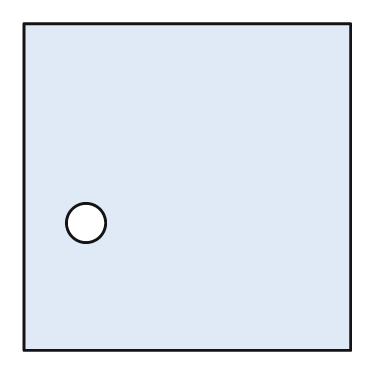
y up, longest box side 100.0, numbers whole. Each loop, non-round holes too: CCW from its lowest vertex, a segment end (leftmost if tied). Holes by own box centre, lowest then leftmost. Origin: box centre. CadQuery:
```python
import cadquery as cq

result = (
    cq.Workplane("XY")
    .moveTo(-50.0, -50.0)
    .lineTo(50.0, -50.0)
    .lineTo(50.0, 50.0)
    .lineTo(-50.0, 50.0)
    .close()
    .moveTo(-31.0, -11.0)
    .circle(6.0)
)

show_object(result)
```